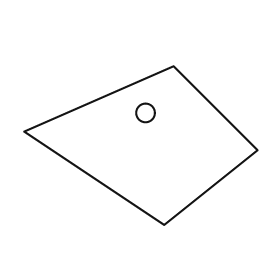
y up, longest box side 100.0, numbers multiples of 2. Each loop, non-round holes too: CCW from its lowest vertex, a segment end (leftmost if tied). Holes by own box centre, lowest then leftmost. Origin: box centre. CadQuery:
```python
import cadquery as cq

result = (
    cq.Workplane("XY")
    .moveTo(10.0, -34.0)
    .lineTo(50.0, -2.0)
    .lineTo(14.0, 34.0)
    .lineTo(-50.0, 6.0)
    .close()
    .moveTo(2.0, 14.0)
    .circle(4.0)
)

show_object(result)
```